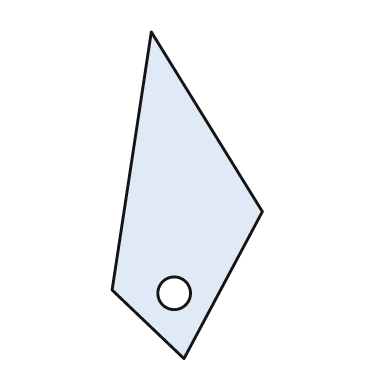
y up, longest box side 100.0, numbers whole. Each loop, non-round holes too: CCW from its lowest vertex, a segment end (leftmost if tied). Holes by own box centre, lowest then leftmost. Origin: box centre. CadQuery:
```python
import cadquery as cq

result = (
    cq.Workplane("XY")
    .moveTo(-1.0, -50.0)
    .lineTo(23.0, -5.0)
    .lineTo(-11.0, 50.0)
    .lineTo(-23.0, -29.0)
    .close()
    .moveTo(-4.0, -30.0)
    .circle(5.0)
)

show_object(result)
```